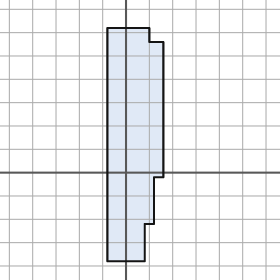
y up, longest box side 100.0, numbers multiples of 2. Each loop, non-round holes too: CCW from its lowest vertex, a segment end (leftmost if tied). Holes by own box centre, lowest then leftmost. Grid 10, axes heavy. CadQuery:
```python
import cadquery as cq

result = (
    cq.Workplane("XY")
    .moveTo(-8.0, -38.0)
    .lineTo(8.0, -38.0)
    .lineTo(8.0, -22.0)
    .lineTo(12.0, -22.0)
    .lineTo(12.0, -2.0)
    .lineTo(16.0, -2.0)
    .lineTo(16.0, 56.0)
    .lineTo(10.0, 56.0)
    .lineTo(10.0, 62.0)
    .lineTo(-8.0, 62.0)
    .close()
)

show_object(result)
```